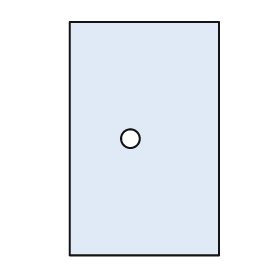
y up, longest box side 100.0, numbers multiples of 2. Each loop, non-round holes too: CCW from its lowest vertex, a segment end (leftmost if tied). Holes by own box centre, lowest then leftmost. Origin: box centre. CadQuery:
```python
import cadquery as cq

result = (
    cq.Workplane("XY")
    .moveTo(-32.0, -50.0)
    .lineTo(32.0, -50.0)
    .lineTo(32.0, 50.0)
    .lineTo(-32.0, 50.0)
    .close()
    .moveTo(-6.0, 0.0)
    .circle(4.0)
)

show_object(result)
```